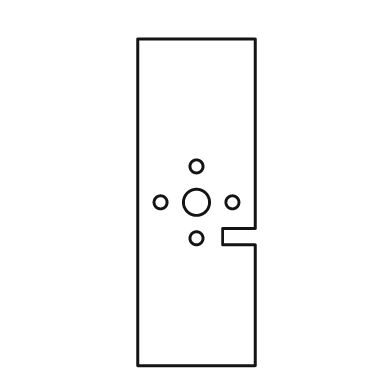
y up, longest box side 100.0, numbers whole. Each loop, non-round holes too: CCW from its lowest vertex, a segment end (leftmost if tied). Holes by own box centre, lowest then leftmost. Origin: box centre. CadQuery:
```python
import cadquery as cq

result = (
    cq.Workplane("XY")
    .moveTo(-18.0, -50.0)
    .lineTo(18.0, -50.0)
    .lineTo(18.0, -13.0)
    .lineTo(8.0, -13.0)
    .lineTo(8.0, -8.0)
    .lineTo(18.0, -8.0)
    .lineTo(18.0, 50.0)
    .lineTo(-18.0, 50.0)
    .close()
    .moveTo(0.0, -11.0)
    .circle(2.0)
    .moveTo(-11.0, 0.0)
    .circle(2.0)
    .moveTo(0.0, 0.0)
    .circle(4.0)
    .moveTo(11.0, 0.0)
    .circle(2.0)
    .moveTo(0.0, 11.0)
    .circle(2.0)
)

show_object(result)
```